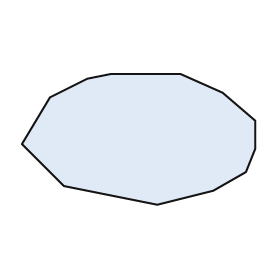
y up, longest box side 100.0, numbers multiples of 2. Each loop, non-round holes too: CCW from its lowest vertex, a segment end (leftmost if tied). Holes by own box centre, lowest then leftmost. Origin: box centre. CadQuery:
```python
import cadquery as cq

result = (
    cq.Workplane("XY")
    .moveTo(8.0, -28.0)
    .lineTo(32.0, -22.0)
    .lineTo(46.0, -14.0)
    .lineTo(50.0, -4.0)
    .lineTo(50.0, 8.0)
    .lineTo(36.0, 20.0)
    .lineTo(18.0, 28.0)
    .lineTo(-12.0, 28.0)
    .lineTo(-22.0, 26.0)
    .lineTo(-38.0, 18.0)
    .lineTo(-50.0, -2.0)
    .lineTo(-32.0, -20.0)
    .close()
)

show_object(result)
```